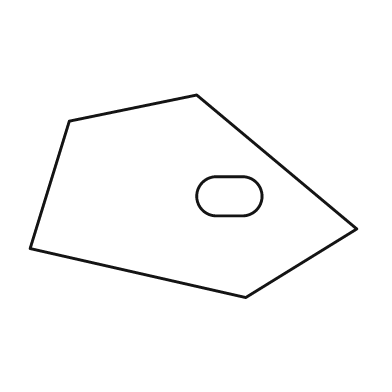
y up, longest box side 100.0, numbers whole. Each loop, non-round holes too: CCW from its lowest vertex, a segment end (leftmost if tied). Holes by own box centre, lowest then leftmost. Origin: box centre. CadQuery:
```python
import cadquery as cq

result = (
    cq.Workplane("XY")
    .moveTo(16.0, -31.0)
    .lineTo(50.0, -10.0)
    .lineTo(1.0, 31.0)
    .lineTo(-38.0, 23.0)
    .lineTo(-50.0, -16.0)
    .close()
    .moveTo(7.0, -6.0)
    .lineTo(15.0, -6.0)
    .threePointArc((21.0, 0.0), (15.0, 6.0))
    .lineTo(7.0, 6.0)
    .threePointArc((1.0, 0.0), (7.0, -6.0))
    .close()
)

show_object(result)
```